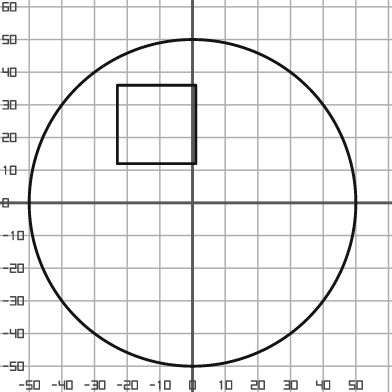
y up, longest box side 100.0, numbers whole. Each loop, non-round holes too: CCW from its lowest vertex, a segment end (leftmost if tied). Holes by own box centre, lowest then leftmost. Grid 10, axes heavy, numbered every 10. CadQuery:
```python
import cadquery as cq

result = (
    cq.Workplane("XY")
    .moveTo(0.0, 0.0)
    .circle(50.0)
    .moveTo(-23.0, 12.0)
    .lineTo(1.0, 12.0)
    .lineTo(1.0, 36.0)
    .lineTo(-23.0, 36.0)
    .close()
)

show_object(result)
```